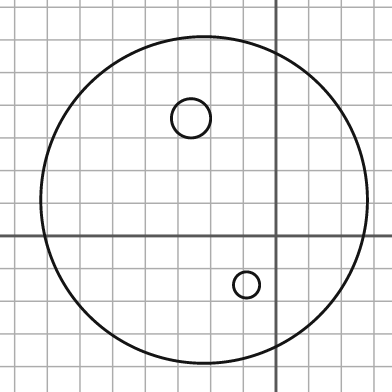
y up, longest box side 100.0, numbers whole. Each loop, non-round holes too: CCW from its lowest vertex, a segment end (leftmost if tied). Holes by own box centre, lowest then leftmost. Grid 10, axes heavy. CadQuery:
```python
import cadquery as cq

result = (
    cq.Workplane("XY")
    .moveTo(-22.0, 11.0)
    .circle(50.0)
    .moveTo(-9.0, -15.0)
    .circle(4.0)
    .moveTo(-26.0, 36.0)
    .circle(6.0)
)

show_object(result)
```